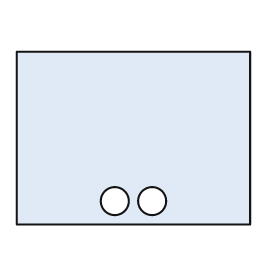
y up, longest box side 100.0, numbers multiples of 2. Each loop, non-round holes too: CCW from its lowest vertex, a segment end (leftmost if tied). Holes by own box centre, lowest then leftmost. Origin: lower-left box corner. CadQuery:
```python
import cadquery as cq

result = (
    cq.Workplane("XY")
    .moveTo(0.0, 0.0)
    .lineTo(100.0, 0.0)
    .lineTo(100.0, 74.0)
    .lineTo(0.0, 74.0)
    .close()
    .moveTo(42.0, 10.0)
    .circle(6.0)
    .moveTo(58.0, 10.0)
    .circle(6.0)
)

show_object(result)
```